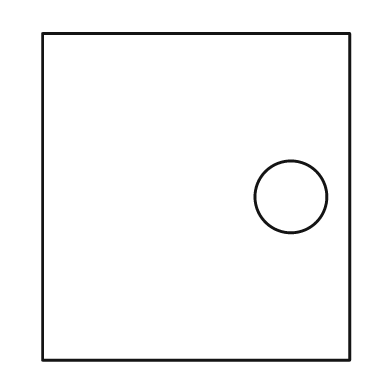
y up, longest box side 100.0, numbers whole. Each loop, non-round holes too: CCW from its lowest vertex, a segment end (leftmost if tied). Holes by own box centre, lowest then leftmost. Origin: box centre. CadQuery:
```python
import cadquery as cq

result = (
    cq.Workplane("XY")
    .moveTo(-47.0, -50.0)
    .lineTo(47.0, -50.0)
    .lineTo(47.0, 50.0)
    .lineTo(-47.0, 50.0)
    .close()
    .moveTo(29.0, 0.0)
    .circle(11.0)
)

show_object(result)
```